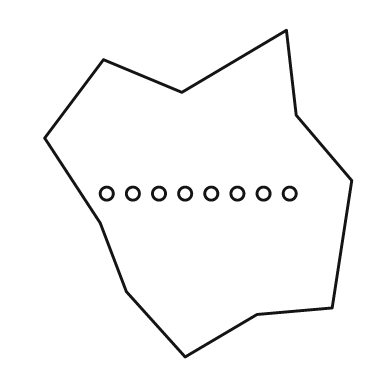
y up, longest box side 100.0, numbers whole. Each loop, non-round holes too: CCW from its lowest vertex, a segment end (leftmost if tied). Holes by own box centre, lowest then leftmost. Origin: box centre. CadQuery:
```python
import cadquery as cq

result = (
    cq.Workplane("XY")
    .moveTo(-4.0, -50.0)
    .lineTo(18.0, -37.0)
    .lineTo(41.0, -35.0)
    .lineTo(47.0, 4.0)
    .lineTo(30.0, 24.0)
    .lineTo(27.0, 50.0)
    .lineTo(-5.0, 31.0)
    .lineTo(-29.0, 41.0)
    .lineTo(-47.0, 17.0)
    .lineTo(-30.0, -9.0)
    .lineTo(-22.0, -30.0)
    .close()
    .moveTo(-28.0, 0.0)
    .circle(2.0)
    .moveTo(-20.0, 0.0)
    .circle(2.0)
    .moveTo(-12.0, 0.0)
    .circle(2.0)
    .moveTo(-4.0, 0.0)
    .circle(2.0)
    .moveTo(4.0, 0.0)
    .circle(2.0)
    .moveTo(12.0, 0.0)
    .circle(2.0)
    .moveTo(20.0, 0.0)
    .circle(2.0)
    .moveTo(28.0, 0.0)
    .circle(2.0)
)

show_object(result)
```